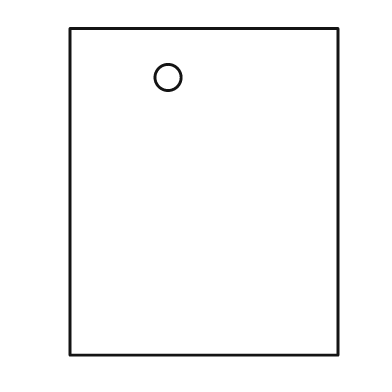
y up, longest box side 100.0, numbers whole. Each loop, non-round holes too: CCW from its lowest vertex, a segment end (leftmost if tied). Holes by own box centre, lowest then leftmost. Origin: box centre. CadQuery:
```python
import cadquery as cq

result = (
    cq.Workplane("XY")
    .moveTo(-41.0, -50.0)
    .lineTo(41.0, -50.0)
    .lineTo(41.0, 50.0)
    .lineTo(-41.0, 50.0)
    .close()
    .moveTo(-11.0, 35.0)
    .circle(4.0)
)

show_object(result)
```